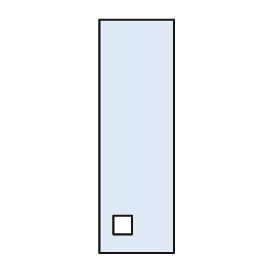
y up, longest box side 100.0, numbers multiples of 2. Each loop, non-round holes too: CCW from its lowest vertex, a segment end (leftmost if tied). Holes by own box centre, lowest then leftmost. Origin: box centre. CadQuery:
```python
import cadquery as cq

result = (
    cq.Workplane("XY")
    .moveTo(-16.0, -50.0)
    .lineTo(16.0, -50.0)
    .lineTo(16.0, 50.0)
    .lineTo(-16.0, 50.0)
    .close()
    .moveTo(-10.0, -42.0)
    .lineTo(-2.0, -42.0)
    .lineTo(-2.0, -34.0)
    .lineTo(-10.0, -34.0)
    .close()
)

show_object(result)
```